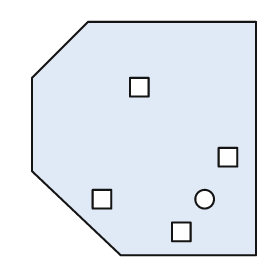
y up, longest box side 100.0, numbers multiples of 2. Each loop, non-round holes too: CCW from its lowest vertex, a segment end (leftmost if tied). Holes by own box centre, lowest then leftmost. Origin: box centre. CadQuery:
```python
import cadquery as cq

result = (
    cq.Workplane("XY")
    .moveTo(-10.0, -50.0)
    .lineTo(48.0, -50.0)
    .lineTo(48.0, 50.0)
    .lineTo(-24.0, 50.0)
    .lineTo(-48.0, 26.0)
    .lineTo(-48.0, -14.0)
    .close()
    .moveTo(12.0, -44.0)
    .lineTo(20.0, -44.0)
    .lineTo(20.0, -36.0)
    .lineTo(12.0, -36.0)
    .close()
    .moveTo(-22.0, -30.0)
    .lineTo(-14.0, -30.0)
    .lineTo(-14.0, -22.0)
    .lineTo(-22.0, -22.0)
    .close()
    .moveTo(26.0, -26.0)
    .circle(4.0)
    .moveTo(32.0, -12.0)
    .lineTo(40.0, -12.0)
    .lineTo(40.0, -4.0)
    .lineTo(32.0, -4.0)
    .close()
    .moveTo(-6.0, 18.0)
    .lineTo(2.0, 18.0)
    .lineTo(2.0, 26.0)
    .lineTo(-6.0, 26.0)
    .close()
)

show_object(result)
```